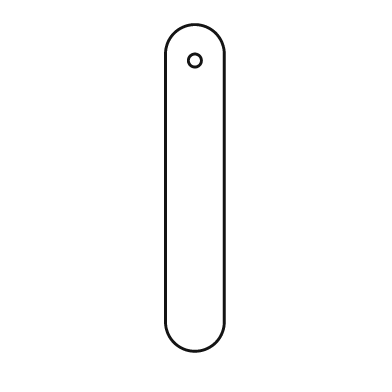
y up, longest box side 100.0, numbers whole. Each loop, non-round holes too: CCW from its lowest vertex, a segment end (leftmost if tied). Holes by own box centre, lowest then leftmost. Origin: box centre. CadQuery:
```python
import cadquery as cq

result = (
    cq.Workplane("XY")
    .moveTo(-9.0, -41.0)
    .threePointArc((0.0, -50.0), (9.0, -41.0))
    .lineTo(9.0, 41.0)
    .threePointArc((0.0, 50.0), (-9.0, 41.0))
    .close()
    .moveTo(0.0, 39.0)
    .circle(2.0)
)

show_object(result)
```